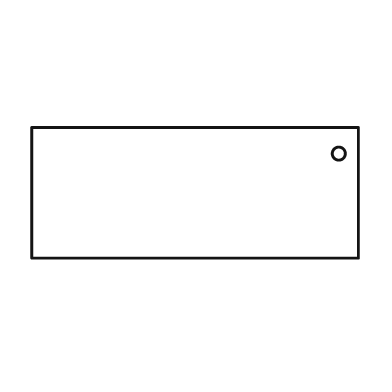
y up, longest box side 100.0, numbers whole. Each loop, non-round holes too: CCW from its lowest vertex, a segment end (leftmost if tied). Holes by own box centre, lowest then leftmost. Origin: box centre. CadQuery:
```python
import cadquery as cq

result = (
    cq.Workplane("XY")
    .moveTo(-50.0, -20.0)
    .lineTo(50.0, -20.0)
    .lineTo(50.0, 20.0)
    .lineTo(-50.0, 20.0)
    .close()
    .moveTo(44.0, 12.0)
    .circle(2.0)
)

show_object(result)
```